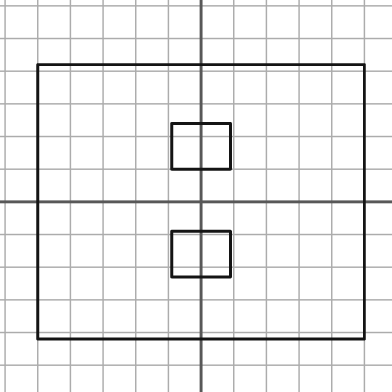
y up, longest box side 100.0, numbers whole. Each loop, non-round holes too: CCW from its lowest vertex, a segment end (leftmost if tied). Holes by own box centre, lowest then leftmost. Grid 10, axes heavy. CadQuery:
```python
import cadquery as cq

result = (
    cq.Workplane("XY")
    .moveTo(-50.0, -42.0)
    .lineTo(50.0, -42.0)
    .lineTo(50.0, 42.0)
    .lineTo(-50.0, 42.0)
    .close()
    .moveTo(-9.0, -23.0)
    .lineTo(9.0, -23.0)
    .lineTo(9.0, -9.0)
    .lineTo(-9.0, -9.0)
    .close()
    .moveTo(-9.0, 10.0)
    .lineTo(9.0, 10.0)
    .lineTo(9.0, 24.0)
    .lineTo(-9.0, 24.0)
    .close()
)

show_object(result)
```